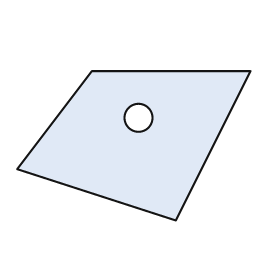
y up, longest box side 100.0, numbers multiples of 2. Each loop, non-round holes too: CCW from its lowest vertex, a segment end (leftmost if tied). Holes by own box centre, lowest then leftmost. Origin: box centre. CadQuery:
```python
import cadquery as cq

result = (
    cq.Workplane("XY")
    .moveTo(18.0, -32.0)
    .lineTo(50.0, 32.0)
    .lineTo(-18.0, 32.0)
    .lineTo(-50.0, -10.0)
    .close()
    .moveTo(2.0, 12.0)
    .circle(6.0)
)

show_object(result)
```